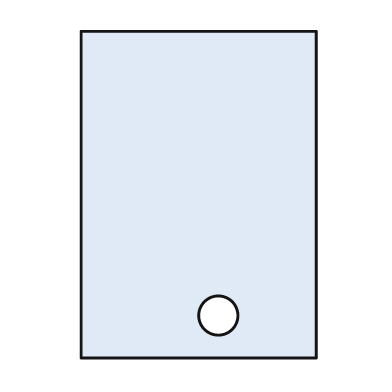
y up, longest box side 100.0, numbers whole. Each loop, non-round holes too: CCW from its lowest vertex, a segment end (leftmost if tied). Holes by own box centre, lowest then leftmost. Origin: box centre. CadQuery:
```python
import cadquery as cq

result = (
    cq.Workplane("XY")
    .moveTo(-36.0, -50.0)
    .lineTo(36.0, -50.0)
    .lineTo(36.0, 50.0)
    .lineTo(-36.0, 50.0)
    .close()
    .moveTo(6.0, -37.0)
    .circle(6.0)
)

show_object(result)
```